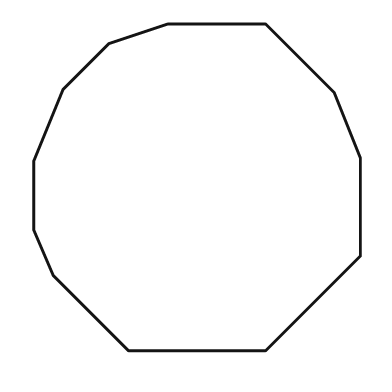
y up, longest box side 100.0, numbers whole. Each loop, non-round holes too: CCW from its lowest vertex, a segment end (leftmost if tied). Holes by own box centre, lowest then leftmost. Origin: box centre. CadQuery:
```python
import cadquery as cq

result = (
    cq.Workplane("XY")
    .moveTo(-21.0, -50.0)
    .lineTo(21.0, -50.0)
    .lineTo(50.0, -21.0)
    .lineTo(50.0, 9.0)
    .lineTo(42.0, 29.0)
    .lineTo(21.0, 50.0)
    .lineTo(-9.0, 50.0)
    .lineTo(-27.0, 44.0)
    .lineTo(-41.0, 30.0)
    .lineTo(-50.0, 8.0)
    .lineTo(-50.0, -13.0)
    .lineTo(-44.0, -27.0)
    .close()
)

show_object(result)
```